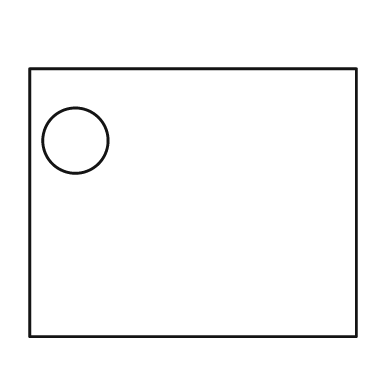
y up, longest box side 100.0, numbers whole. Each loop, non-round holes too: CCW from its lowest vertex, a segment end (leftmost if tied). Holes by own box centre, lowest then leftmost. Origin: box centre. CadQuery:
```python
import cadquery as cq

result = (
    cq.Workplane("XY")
    .moveTo(-50.0, -41.0)
    .lineTo(50.0, -41.0)
    .lineTo(50.0, 41.0)
    .lineTo(-50.0, 41.0)
    .close()
    .moveTo(-36.0, 19.0)
    .circle(10.0)
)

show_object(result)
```